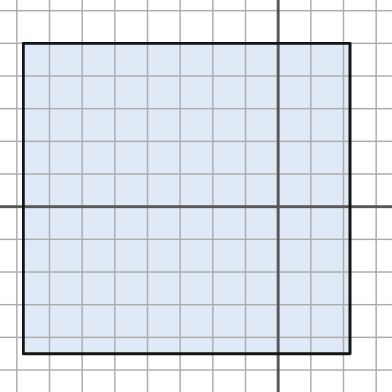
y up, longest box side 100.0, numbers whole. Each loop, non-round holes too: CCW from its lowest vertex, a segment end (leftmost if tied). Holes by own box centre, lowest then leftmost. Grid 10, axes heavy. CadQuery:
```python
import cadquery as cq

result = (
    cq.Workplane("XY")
    .moveTo(-78.0, -45.0)
    .lineTo(22.0, -45.0)
    .lineTo(22.0, 50.0)
    .lineTo(-78.0, 50.0)
    .close()
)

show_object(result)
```